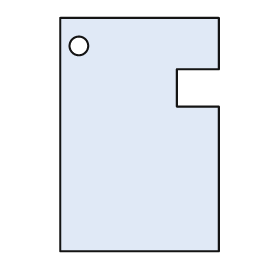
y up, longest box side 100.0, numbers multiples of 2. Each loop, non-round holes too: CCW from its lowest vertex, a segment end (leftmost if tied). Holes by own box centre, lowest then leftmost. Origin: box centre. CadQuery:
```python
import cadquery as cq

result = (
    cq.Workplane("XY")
    .moveTo(-34.0, -50.0)
    .lineTo(34.0, -50.0)
    .lineTo(34.0, 12.0)
    .lineTo(16.0, 12.0)
    .lineTo(16.0, 28.0)
    .lineTo(34.0, 28.0)
    .lineTo(34.0, 50.0)
    .lineTo(-34.0, 50.0)
    .close()
    .moveTo(-26.0, 38.0)
    .circle(4.0)
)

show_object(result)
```